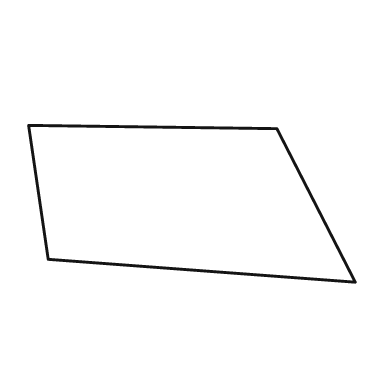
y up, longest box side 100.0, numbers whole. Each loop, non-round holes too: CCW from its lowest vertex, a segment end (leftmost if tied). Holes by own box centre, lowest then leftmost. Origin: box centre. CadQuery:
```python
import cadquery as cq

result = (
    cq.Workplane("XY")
    .moveTo(50.0, -24.0)
    .lineTo(26.0, 23.0)
    .lineTo(-50.0, 24.0)
    .lineTo(-44.0, -17.0)
    .close()
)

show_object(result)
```